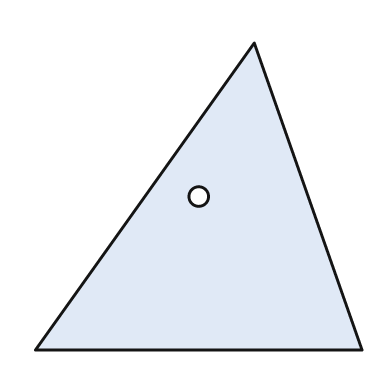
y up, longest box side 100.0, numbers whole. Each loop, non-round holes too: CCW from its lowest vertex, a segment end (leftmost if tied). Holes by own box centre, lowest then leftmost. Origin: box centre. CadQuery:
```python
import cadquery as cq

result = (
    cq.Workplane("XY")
    .moveTo(-50.0, -47.0)
    .lineTo(50.0, -47.0)
    .lineTo(17.0, 47.0)
    .close()
    .moveTo(0.0, 0.0)
    .circle(3.0)
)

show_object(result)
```